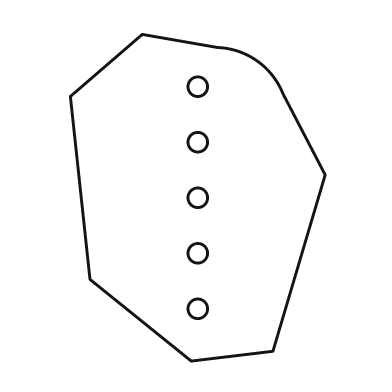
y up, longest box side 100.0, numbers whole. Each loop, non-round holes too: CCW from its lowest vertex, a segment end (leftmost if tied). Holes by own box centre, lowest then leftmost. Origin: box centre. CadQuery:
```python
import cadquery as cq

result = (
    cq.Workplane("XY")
    .moveTo(-2.0, -50.0)
    .lineTo(23.0, -47.0)
    .lineTo(39.0, 7.0)
    .lineTo(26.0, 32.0)
    .threePointArc((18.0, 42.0), (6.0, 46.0))
    .lineTo(-17.0, 50.0)
    .lineTo(-39.0, 31.0)
    .lineTo(-33.0, -25.0)
    .close()
    .moveTo(0.0, -34.0)
    .circle(3.0)
    .moveTo(0.0, -17.0)
    .circle(3.0)
    .moveTo(0.0, 0.0)
    .circle(3.0)
    .moveTo(0.0, 17.0)
    .circle(3.0)
    .moveTo(0.0, 34.0)
    .circle(3.0)
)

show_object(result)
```